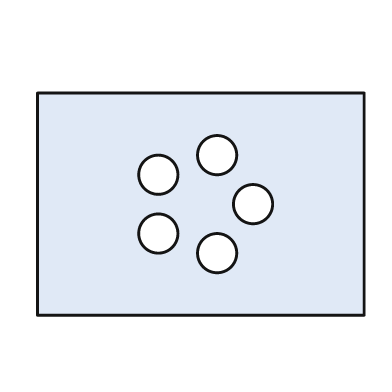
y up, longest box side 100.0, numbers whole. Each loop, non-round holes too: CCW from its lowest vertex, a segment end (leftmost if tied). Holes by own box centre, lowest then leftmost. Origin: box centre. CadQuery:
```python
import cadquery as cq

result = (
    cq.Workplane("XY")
    .moveTo(-50.0, -34.0)
    .lineTo(50.0, -34.0)
    .lineTo(50.0, 34.0)
    .lineTo(-50.0, 34.0)
    .close()
    .moveTo(5.0, -15.0)
    .circle(6.0)
    .moveTo(-13.0, -9.0)
    .circle(6.0)
    .moveTo(16.0, 0.0)
    .circle(6.0)
    .moveTo(-13.0, 9.0)
    .circle(6.0)
    .moveTo(5.0, 15.0)
    .circle(6.0)
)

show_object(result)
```